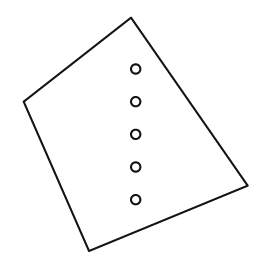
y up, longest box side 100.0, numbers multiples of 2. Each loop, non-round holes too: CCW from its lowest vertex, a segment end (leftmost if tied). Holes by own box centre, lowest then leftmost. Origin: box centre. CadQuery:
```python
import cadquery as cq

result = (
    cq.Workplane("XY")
    .moveTo(-20.0, -50.0)
    .lineTo(48.0, -22.0)
    .lineTo(-2.0, 50.0)
    .lineTo(-48.0, 14.0)
    .close()
    .moveTo(0.0, -28.0)
    .circle(2.0)
    .moveTo(0.0, -14.0)
    .circle(2.0)
    .moveTo(0.0, 0.0)
    .circle(2.0)
    .moveTo(0.0, 14.0)
    .circle(2.0)
    .moveTo(0.0, 28.0)
    .circle(2.0)
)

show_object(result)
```